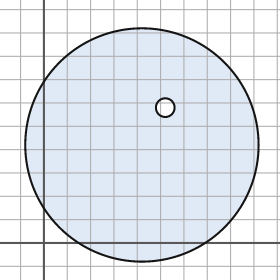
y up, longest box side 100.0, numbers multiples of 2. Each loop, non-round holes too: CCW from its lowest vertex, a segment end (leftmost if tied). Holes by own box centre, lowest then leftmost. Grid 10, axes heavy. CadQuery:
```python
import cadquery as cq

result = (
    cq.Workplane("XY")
    .moveTo(42.0, 42.0)
    .circle(50.0)
    .moveTo(52.0, 58.0)
    .circle(4.0)
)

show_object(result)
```